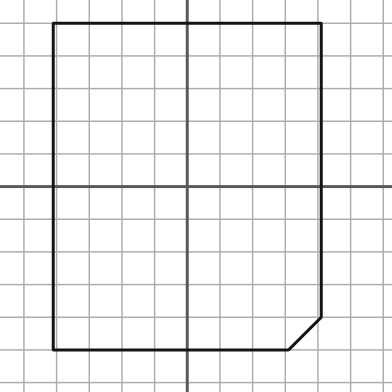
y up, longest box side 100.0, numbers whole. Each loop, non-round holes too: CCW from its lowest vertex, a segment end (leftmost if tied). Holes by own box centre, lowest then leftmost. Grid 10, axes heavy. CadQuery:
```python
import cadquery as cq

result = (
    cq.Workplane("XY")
    .moveTo(-41.0, -50.0)
    .lineTo(31.0, -50.0)
    .lineTo(41.0, -40.0)
    .lineTo(41.0, 50.0)
    .lineTo(-41.0, 50.0)
    .close()
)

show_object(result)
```